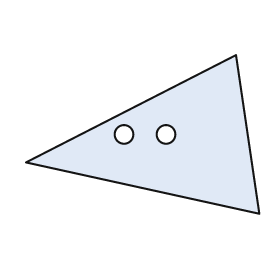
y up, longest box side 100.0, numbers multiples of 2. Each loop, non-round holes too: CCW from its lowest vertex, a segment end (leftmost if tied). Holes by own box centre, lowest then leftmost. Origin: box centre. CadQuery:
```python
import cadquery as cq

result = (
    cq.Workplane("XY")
    .moveTo(50.0, -34.0)
    .lineTo(40.0, 34.0)
    .lineTo(-50.0, -12.0)
    .close()
    .moveTo(-8.0, 0.0)
    .circle(4.0)
    .moveTo(10.0, 0.0)
    .circle(4.0)
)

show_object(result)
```